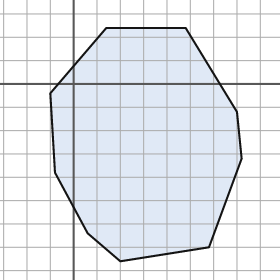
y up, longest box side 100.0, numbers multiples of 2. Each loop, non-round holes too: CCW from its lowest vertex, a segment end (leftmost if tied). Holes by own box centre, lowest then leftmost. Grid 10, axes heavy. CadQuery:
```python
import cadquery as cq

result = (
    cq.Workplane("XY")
    .moveTo(20.0, -76.0)
    .lineTo(58.0, -70.0)
    .lineTo(72.0, -32.0)
    .lineTo(70.0, -12.0)
    .lineTo(48.0, 24.0)
    .lineTo(14.0, 24.0)
    .lineTo(-10.0, -4.0)
    .lineTo(-8.0, -38.0)
    .lineTo(6.0, -64.0)
    .close()
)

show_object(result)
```